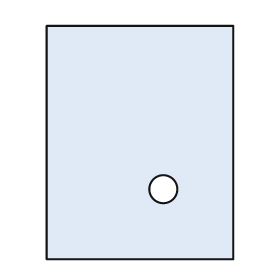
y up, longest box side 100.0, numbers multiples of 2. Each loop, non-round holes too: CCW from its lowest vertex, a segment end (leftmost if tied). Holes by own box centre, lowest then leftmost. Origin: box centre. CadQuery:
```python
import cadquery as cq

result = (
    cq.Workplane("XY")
    .moveTo(-40.0, -50.0)
    .lineTo(40.0, -50.0)
    .lineTo(40.0, 50.0)
    .lineTo(-40.0, 50.0)
    .close()
    .moveTo(10.0, -20.0)
    .circle(6.0)
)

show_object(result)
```